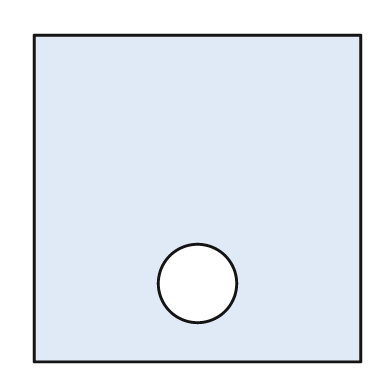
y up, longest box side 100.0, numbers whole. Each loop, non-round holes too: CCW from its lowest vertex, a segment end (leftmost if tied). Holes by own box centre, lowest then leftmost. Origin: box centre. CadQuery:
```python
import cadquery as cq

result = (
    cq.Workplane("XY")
    .moveTo(-50.0, -50.0)
    .lineTo(50.0, -50.0)
    .lineTo(50.0, 50.0)
    .lineTo(-50.0, 50.0)
    .close()
    .moveTo(0.0, -26.0)
    .circle(12.0)
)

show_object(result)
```